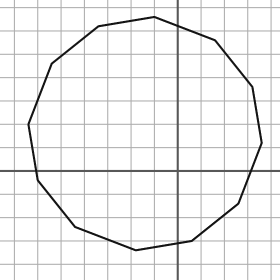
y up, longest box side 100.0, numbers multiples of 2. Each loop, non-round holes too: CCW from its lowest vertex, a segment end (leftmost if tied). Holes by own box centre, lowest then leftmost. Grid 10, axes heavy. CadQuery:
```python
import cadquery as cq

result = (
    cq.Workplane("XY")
    .moveTo(-18.0, -34.0)
    .lineTo(6.0, -30.0)
    .lineTo(26.0, -14.0)
    .lineTo(36.0, 12.0)
    .lineTo(32.0, 36.0)
    .lineTo(16.0, 56.0)
    .lineTo(-10.0, 66.0)
    .lineTo(-34.0, 62.0)
    .lineTo(-54.0, 46.0)
    .lineTo(-64.0, 20.0)
    .lineTo(-60.0, -4.0)
    .lineTo(-44.0, -24.0)
    .close()
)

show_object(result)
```